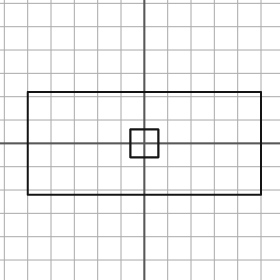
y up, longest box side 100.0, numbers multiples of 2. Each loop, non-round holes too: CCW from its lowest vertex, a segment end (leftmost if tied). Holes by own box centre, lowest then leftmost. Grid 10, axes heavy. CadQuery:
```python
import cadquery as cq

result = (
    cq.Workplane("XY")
    .moveTo(-50.0, -22.0)
    .lineTo(50.0, -22.0)
    .lineTo(50.0, 22.0)
    .lineTo(-50.0, 22.0)
    .close()
    .moveTo(-6.0, -6.0)
    .lineTo(6.0, -6.0)
    .lineTo(6.0, 6.0)
    .lineTo(-6.0, 6.0)
    .close()
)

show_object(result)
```